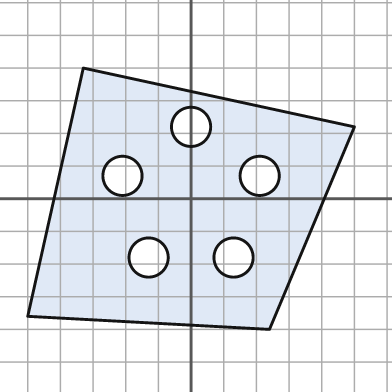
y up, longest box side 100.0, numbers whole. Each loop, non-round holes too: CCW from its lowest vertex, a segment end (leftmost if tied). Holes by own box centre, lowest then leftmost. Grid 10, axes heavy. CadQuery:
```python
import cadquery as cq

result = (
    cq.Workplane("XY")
    .moveTo(24.0, -40.0)
    .lineTo(50.0, 22.0)
    .lineTo(-33.0, 40.0)
    .lineTo(-50.0, -36.0)
    .close()
    .moveTo(-13.0, -18.0)
    .circle(6.0)
    .moveTo(13.0, -18.0)
    .circle(6.0)
    .moveTo(-21.0, 7.0)
    .circle(6.0)
    .moveTo(21.0, 7.0)
    .circle(6.0)
    .moveTo(0.0, 22.0)
    .circle(6.0)
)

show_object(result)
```